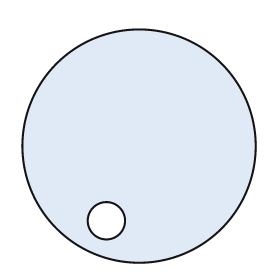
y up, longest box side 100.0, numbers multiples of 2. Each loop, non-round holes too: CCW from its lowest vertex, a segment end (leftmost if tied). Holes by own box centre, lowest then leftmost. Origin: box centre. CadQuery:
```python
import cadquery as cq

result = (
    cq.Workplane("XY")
    .moveTo(0.0, 0.0)
    .circle(50.0)
    .moveTo(-14.0, -32.0)
    .circle(8.0)
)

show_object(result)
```